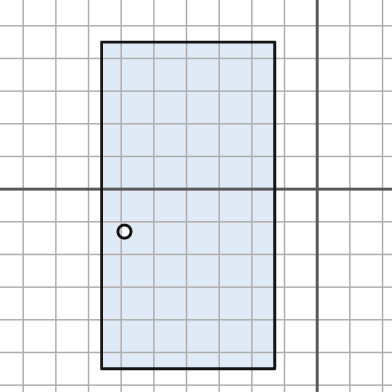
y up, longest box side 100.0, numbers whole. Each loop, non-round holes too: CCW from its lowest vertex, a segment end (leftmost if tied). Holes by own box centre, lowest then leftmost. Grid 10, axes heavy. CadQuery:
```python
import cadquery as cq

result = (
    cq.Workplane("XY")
    .moveTo(-66.0, -55.0)
    .lineTo(-13.0, -55.0)
    .lineTo(-13.0, 45.0)
    .lineTo(-66.0, 45.0)
    .close()
    .moveTo(-59.0, -13.0)
    .circle(2.0)
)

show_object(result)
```